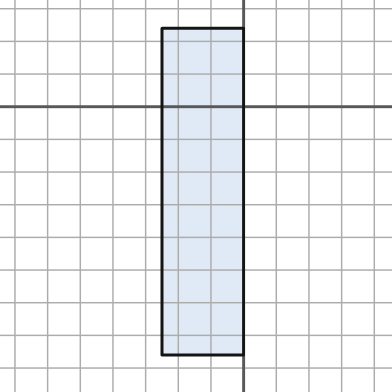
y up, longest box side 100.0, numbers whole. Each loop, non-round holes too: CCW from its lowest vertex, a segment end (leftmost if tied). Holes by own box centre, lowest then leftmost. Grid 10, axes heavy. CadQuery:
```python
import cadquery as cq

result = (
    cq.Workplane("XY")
    .moveTo(-25.0, -76.0)
    .lineTo(0.0, -76.0)
    .lineTo(0.0, 24.0)
    .lineTo(-25.0, 24.0)
    .close()
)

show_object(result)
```